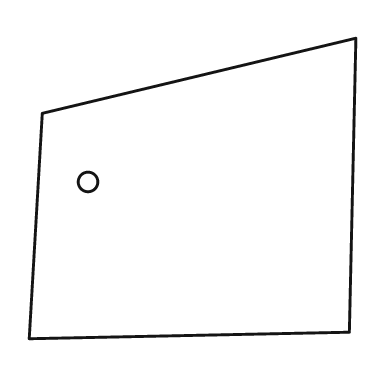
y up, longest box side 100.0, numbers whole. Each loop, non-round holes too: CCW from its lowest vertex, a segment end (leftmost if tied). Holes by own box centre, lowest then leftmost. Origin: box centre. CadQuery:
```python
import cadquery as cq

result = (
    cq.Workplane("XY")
    .moveTo(-50.0, -46.0)
    .lineTo(48.0, -44.0)
    .lineTo(50.0, 46.0)
    .lineTo(-46.0, 23.0)
    .close()
    .moveTo(-32.0, 2.0)
    .circle(3.0)
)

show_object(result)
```